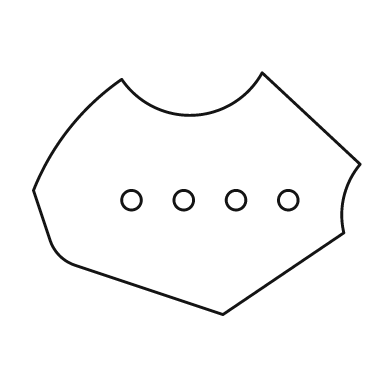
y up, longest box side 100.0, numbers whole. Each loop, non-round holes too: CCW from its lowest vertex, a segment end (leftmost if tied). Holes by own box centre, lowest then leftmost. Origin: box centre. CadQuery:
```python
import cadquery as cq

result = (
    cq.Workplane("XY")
    .moveTo(8.0, -37.0)
    .lineTo(45.0, -12.0)
    .threePointArc((45.0, -1.0), (50.0, 9.0))
    .lineTo(20.0, 37.0)
    .threePointArc((-1.0, 24.0), (-23.0, 35.0))
    .threePointArc((-39.0, 20.0), (-50.0, 1.0))
    .lineTo(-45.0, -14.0)
    .threePointArc((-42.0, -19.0), (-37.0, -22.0))
    .close()
    .moveTo(-20.0, -2.0)
    .circle(3.0)
    .moveTo(-4.0, -2.0)
    .circle(3.0)
    .moveTo(12.0, -2.0)
    .circle(3.0)
    .moveTo(28.0, -2.0)
    .circle(3.0)
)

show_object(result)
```